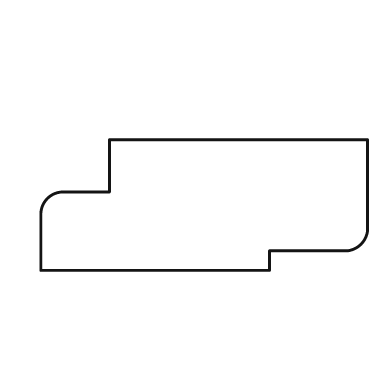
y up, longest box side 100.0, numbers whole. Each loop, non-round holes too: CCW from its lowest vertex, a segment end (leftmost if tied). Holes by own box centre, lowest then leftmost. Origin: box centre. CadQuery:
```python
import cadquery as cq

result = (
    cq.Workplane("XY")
    .moveTo(-50.0, -20.0)
    .lineTo(20.0, -20.0)
    .lineTo(20.0, -14.0)
    .lineTo(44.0, -14.0)
    .threePointArc((48.0, -12.0), (50.0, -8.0))
    .lineTo(50.0, 20.0)
    .lineTo(-29.0, 20.0)
    .lineTo(-29.0, 4.0)
    .lineTo(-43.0, 4.0)
    .threePointArc((-48.0, 2.0), (-50.0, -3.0))
    .close()
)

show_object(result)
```